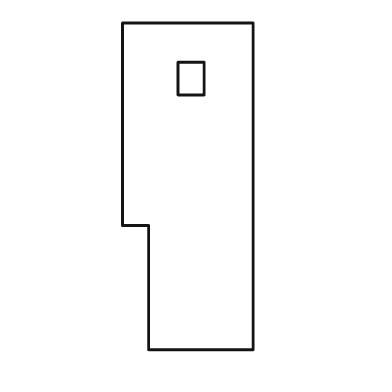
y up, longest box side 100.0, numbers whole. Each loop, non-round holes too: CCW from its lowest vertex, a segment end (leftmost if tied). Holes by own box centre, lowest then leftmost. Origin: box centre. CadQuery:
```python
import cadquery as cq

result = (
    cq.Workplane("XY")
    .moveTo(-12.0, -50.0)
    .lineTo(20.0, -50.0)
    .lineTo(20.0, 50.0)
    .lineTo(-20.0, 50.0)
    .lineTo(-20.0, -12.0)
    .lineTo(-12.0, -12.0)
    .close()
    .moveTo(-3.0, 28.0)
    .lineTo(5.0, 28.0)
    .lineTo(5.0, 38.0)
    .lineTo(-3.0, 38.0)
    .close()
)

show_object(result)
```